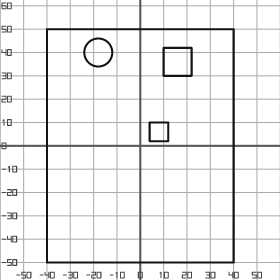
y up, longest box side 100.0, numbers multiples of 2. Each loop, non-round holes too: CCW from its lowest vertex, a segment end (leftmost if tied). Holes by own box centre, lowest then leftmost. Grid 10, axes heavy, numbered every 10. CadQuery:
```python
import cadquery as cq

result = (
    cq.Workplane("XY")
    .moveTo(-40.0, -50.0)
    .lineTo(40.0, -50.0)
    .lineTo(40.0, 50.0)
    .lineTo(-40.0, 50.0)
    .close()
    .moveTo(4.0, 2.0)
    .lineTo(12.0, 2.0)
    .lineTo(12.0, 10.0)
    .lineTo(4.0, 10.0)
    .close()
    .moveTo(10.0, 30.0)
    .lineTo(22.0, 30.0)
    .lineTo(22.0, 42.0)
    .lineTo(10.0, 42.0)
    .close()
    .moveTo(-18.0, 40.0)
    .circle(6.0)
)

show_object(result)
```